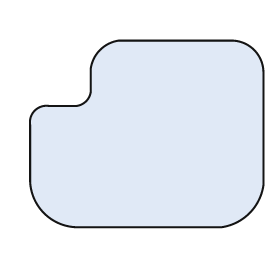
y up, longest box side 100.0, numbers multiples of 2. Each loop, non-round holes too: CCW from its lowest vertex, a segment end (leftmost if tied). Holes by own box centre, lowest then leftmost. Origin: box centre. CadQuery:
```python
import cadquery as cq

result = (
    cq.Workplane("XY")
    .moveTo(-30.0, -40.0)
    .lineTo(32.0, -40.0)
    .threePointArc((44.0, -34.0), (50.0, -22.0))
    .lineTo(50.0, 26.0)
    .threePointArc((46.0, 36.0), (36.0, 40.0))
    .lineTo(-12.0, 40.0)
    .threePointArc((-20.0, 36.0), (-24.0, 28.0))
    .lineTo(-24.0, 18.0)
    .threePointArc((-26.0, 14.0), (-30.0, 12.0))
    .lineTo(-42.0, 12.0)
    .threePointArc((-48.0, 10.0), (-50.0, 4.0))
    .lineTo(-50.0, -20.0)
    .threePointArc((-44.0, -34.0), (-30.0, -40.0))
    .close()
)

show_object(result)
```